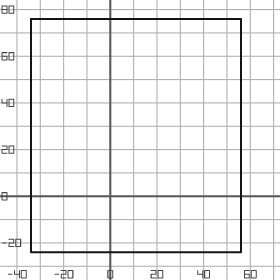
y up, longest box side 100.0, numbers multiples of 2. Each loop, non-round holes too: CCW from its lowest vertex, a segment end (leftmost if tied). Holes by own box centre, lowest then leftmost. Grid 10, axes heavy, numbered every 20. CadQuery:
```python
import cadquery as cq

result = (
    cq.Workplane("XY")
    .moveTo(-34.0, -24.0)
    .lineTo(56.0, -24.0)
    .lineTo(56.0, 76.0)
    .lineTo(-34.0, 76.0)
    .close()
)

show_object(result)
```